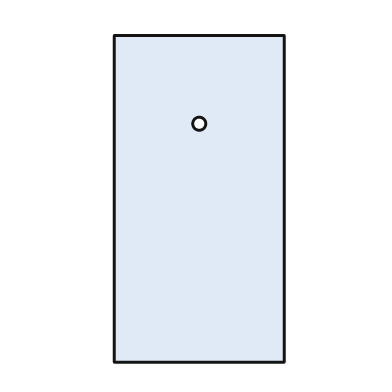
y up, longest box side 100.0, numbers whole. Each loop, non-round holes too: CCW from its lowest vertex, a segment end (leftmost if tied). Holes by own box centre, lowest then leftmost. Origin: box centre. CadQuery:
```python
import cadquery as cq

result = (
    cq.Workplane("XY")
    .moveTo(-26.0, -50.0)
    .lineTo(26.0, -50.0)
    .lineTo(26.0, 50.0)
    .lineTo(-26.0, 50.0)
    .close()
    .moveTo(0.0, 23.0)
    .circle(2.0)
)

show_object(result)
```